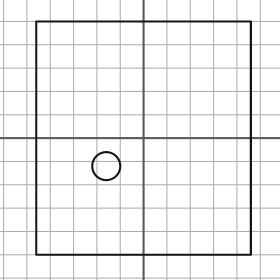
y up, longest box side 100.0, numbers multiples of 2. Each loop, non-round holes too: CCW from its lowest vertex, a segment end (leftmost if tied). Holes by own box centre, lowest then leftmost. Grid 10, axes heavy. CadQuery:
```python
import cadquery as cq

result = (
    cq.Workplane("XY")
    .moveTo(-46.0, -50.0)
    .lineTo(46.0, -50.0)
    .lineTo(46.0, 50.0)
    .lineTo(-46.0, 50.0)
    .close()
    .moveTo(-16.0, -12.0)
    .circle(6.0)
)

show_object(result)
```